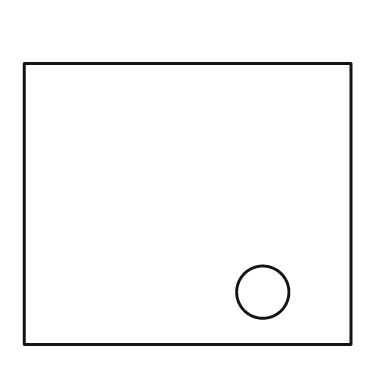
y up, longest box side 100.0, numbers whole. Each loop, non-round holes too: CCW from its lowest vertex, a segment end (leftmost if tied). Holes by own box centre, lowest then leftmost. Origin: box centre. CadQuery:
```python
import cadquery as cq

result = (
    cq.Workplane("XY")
    .moveTo(-50.0, -43.0)
    .lineTo(50.0, -43.0)
    .lineTo(50.0, 43.0)
    .lineTo(-50.0, 43.0)
    .close()
    .moveTo(23.0, -27.0)
    .circle(8.0)
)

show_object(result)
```